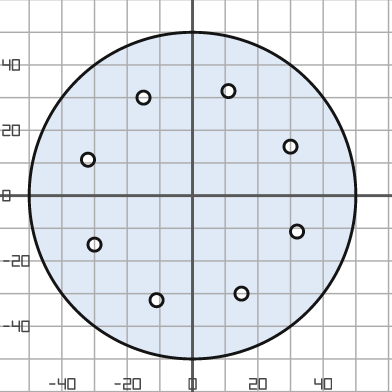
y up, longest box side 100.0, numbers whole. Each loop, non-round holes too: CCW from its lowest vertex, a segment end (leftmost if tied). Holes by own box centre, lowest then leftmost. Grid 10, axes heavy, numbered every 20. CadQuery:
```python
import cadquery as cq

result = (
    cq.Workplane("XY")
    .moveTo(0.0, 0.0)
    .circle(50.0)
    .moveTo(-11.0, -32.0)
    .circle(2.0)
    .moveTo(15.0, -30.0)
    .circle(2.0)
    .moveTo(-30.0, -15.0)
    .circle(2.0)
    .moveTo(32.0, -11.0)
    .circle(2.0)
    .moveTo(-32.0, 11.0)
    .circle(2.0)
    .moveTo(30.0, 15.0)
    .circle(2.0)
    .moveTo(-15.0, 30.0)
    .circle(2.0)
    .moveTo(11.0, 32.0)
    .circle(2.0)
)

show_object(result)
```